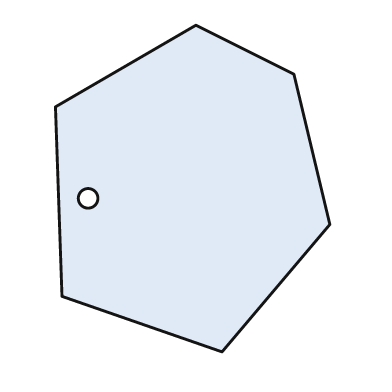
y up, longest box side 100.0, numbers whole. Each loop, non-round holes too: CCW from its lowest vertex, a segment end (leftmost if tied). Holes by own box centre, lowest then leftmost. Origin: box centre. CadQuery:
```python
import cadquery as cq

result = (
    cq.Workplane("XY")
    .moveTo(9.0, -50.0)
    .lineTo(42.0, -11.0)
    .lineTo(31.0, 35.0)
    .lineTo(1.0, 50.0)
    .lineTo(-42.0, 25.0)
    .lineTo(-40.0, -33.0)
    .close()
    .moveTo(-32.0, -3.0)
    .circle(3.0)
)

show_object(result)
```